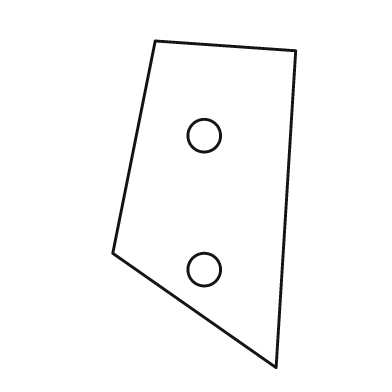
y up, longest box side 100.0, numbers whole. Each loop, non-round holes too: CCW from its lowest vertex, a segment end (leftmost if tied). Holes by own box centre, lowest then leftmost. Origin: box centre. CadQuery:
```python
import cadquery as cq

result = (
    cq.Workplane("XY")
    .moveTo(22.0, -50.0)
    .lineTo(28.0, 47.0)
    .lineTo(-15.0, 50.0)
    .lineTo(-28.0, -15.0)
    .close()
    .moveTo(0.0, -20.0)
    .circle(5.0)
    .moveTo(0.0, 21.0)
    .circle(5.0)
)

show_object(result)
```